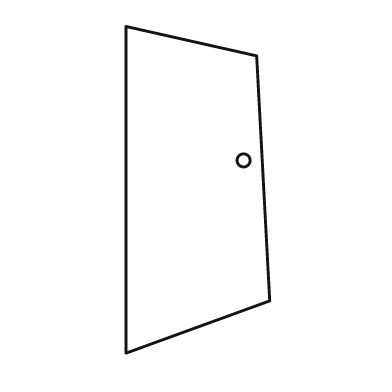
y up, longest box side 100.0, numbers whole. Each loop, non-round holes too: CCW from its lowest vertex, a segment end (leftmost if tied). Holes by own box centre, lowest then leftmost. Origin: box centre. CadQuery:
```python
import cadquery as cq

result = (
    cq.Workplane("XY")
    .moveTo(-22.0, -50.0)
    .lineTo(22.0, -34.0)
    .lineTo(18.0, 41.0)
    .lineTo(-22.0, 50.0)
    .close()
    .moveTo(14.0, 9.0)
    .circle(2.0)
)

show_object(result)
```